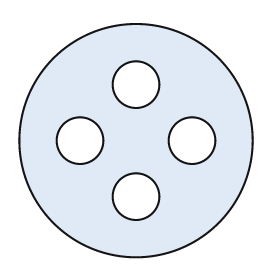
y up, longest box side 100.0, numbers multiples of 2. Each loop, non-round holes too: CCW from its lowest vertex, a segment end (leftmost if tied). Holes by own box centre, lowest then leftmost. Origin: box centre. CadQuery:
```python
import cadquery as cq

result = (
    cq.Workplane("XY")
    .moveTo(0.0, 0.0)
    .circle(50.0)
    .moveTo(0.0, -24.0)
    .circle(10.0)
    .moveTo(-24.0, 0.0)
    .circle(10.0)
    .moveTo(24.0, 0.0)
    .circle(10.0)
    .moveTo(0.0, 24.0)
    .circle(10.0)
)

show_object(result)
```